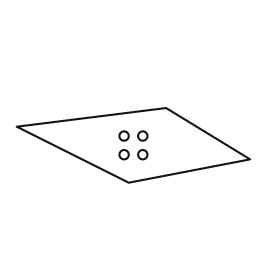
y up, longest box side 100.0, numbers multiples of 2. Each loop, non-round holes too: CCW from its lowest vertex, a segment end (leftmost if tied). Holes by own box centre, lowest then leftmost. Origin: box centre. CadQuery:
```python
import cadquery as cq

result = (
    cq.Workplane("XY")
    .moveTo(-2.0, -16.0)
    .lineTo(50.0, -6.0)
    .lineTo(14.0, 16.0)
    .lineTo(-50.0, 8.0)
    .close()
    .moveTo(-4.0, -4.0)
    .circle(2.0)
    .moveTo(4.0, -4.0)
    .circle(2.0)
    .moveTo(-4.0, 4.0)
    .circle(2.0)
    .moveTo(4.0, 4.0)
    .circle(2.0)
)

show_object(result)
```